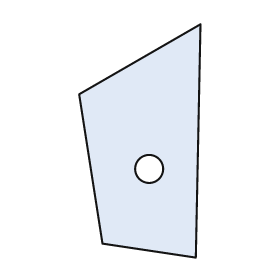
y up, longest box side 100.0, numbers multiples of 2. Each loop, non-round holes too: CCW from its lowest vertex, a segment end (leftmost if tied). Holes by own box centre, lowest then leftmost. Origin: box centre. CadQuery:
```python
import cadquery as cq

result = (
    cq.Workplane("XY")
    .moveTo(24.0, -50.0)
    .lineTo(26.0, 50.0)
    .lineTo(-26.0, 20.0)
    .lineTo(-16.0, -44.0)
    .close()
    .moveTo(4.0, -12.0)
    .circle(6.0)
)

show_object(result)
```